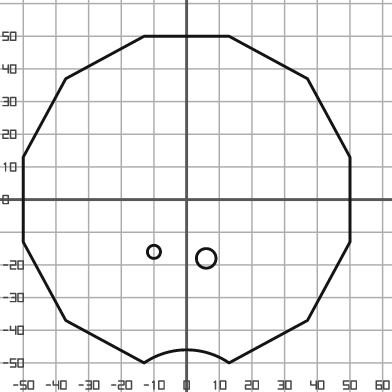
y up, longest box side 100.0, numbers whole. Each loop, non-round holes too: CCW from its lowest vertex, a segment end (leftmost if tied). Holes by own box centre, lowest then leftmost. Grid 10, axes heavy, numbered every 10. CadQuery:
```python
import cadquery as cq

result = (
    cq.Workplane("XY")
    .moveTo(-13.0, -50.0)
    .threePointArc((0.0, -46.0), (13.0, -50.0))
    .lineTo(37.0, -37.0)
    .lineTo(50.0, -13.0)
    .lineTo(50.0, 13.0)
    .lineTo(37.0, 37.0)
    .lineTo(13.0, 50.0)
    .lineTo(-13.0, 50.0)
    .lineTo(-37.0, 37.0)
    .lineTo(-50.0, 13.0)
    .lineTo(-50.0, -13.0)
    .lineTo(-37.0, -37.0)
    .close()
    .moveTo(6.0, -18.0)
    .circle(3.0)
    .moveTo(-10.0, -16.0)
    .circle(2.0)
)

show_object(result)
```